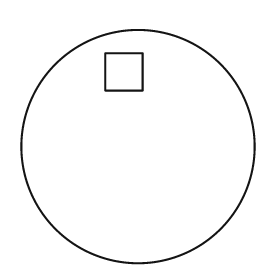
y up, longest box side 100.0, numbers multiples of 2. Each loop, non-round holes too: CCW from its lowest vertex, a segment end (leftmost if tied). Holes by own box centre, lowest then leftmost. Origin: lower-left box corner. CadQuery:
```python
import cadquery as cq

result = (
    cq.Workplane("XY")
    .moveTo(50.0, 50.0)
    .circle(50.0)
    .moveTo(36.0, 74.0)
    .lineTo(52.0, 74.0)
    .lineTo(52.0, 90.0)
    .lineTo(36.0, 90.0)
    .close()
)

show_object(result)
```